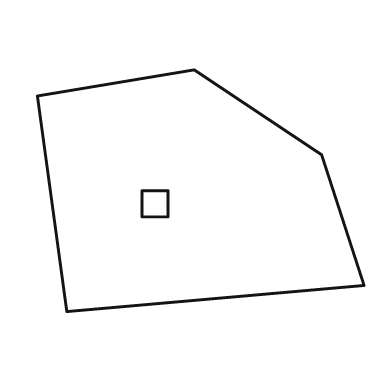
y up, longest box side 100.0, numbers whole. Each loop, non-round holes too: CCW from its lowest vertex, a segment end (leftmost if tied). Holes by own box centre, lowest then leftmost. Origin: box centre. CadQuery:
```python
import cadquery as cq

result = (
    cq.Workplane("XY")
    .moveTo(-41.0, -37.0)
    .lineTo(50.0, -29.0)
    .lineTo(37.0, 11.0)
    .lineTo(-2.0, 37.0)
    .lineTo(-50.0, 29.0)
    .close()
    .moveTo(-18.0, -8.0)
    .lineTo(-10.0, -8.0)
    .lineTo(-10.0, 0.0)
    .lineTo(-18.0, 0.0)
    .close()
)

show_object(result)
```